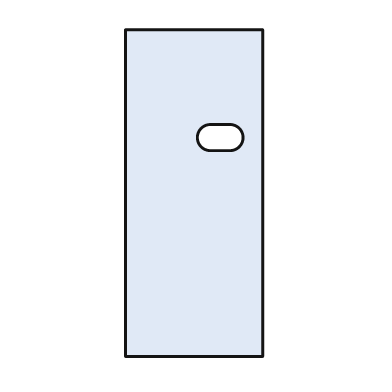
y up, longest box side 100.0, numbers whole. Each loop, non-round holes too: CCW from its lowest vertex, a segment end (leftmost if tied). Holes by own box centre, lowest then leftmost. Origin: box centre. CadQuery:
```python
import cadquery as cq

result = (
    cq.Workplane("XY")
    .moveTo(-21.0, -50.0)
    .lineTo(21.0, -50.0)
    .lineTo(21.0, 50.0)
    .lineTo(-21.0, 50.0)
    .close()
    .moveTo(5.0, 13.0)
    .lineTo(11.0, 13.0)
    .threePointArc((15.0, 17.0), (11.0, 21.0))
    .lineTo(5.0, 21.0)
    .threePointArc((1.0, 17.0), (5.0, 13.0))
    .close()
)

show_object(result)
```